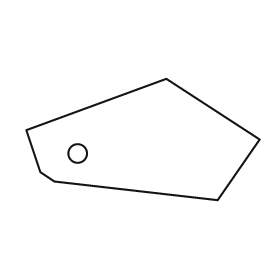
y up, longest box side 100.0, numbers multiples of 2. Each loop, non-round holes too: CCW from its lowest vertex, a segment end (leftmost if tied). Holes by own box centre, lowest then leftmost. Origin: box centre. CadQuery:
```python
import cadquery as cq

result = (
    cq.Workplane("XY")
    .moveTo(32.0, -26.0)
    .lineTo(50.0, 0.0)
    .lineTo(10.0, 26.0)
    .lineTo(-50.0, 4.0)
    .lineTo(-44.0, -14.0)
    .lineTo(-38.0, -18.0)
    .close()
    .moveTo(-28.0, -6.0)
    .circle(4.0)
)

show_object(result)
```